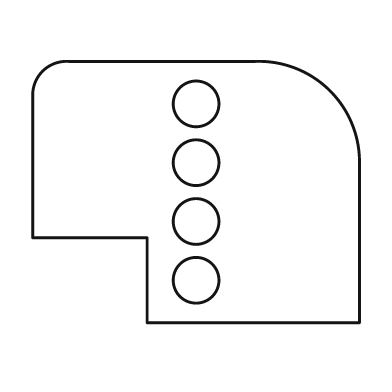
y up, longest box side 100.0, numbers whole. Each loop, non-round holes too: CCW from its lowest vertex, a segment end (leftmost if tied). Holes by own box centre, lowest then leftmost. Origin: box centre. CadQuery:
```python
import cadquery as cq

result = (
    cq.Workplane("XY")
    .moveTo(-15.0, -40.0)
    .lineTo(50.0, -40.0)
    .lineTo(50.0, 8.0)
    .threePointArc((41.0, 31.0), (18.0, 40.0))
    .lineTo(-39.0, 40.0)
    .threePointArc((-47.0, 37.0), (-50.0, 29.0))
    .lineTo(-50.0, -14.0)
    .lineTo(-15.0, -14.0)
    .close()
    .moveTo(0.0, -27.0)
    .circle(7.0)
    .moveTo(0.0, -9.0)
    .circle(7.0)
    .moveTo(0.0, 9.0)
    .circle(7.0)
    .moveTo(0.0, 27.0)
    .circle(7.0)
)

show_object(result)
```